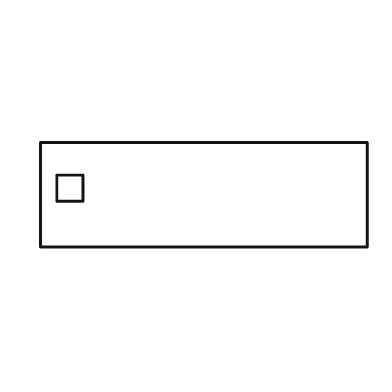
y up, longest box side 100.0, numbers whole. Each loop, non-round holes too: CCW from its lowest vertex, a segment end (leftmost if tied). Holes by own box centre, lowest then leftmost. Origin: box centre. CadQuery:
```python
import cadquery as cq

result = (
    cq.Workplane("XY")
    .moveTo(-50.0, -16.0)
    .lineTo(50.0, -16.0)
    .lineTo(50.0, 16.0)
    .lineTo(-50.0, 16.0)
    .close()
    .moveTo(-45.0, -2.0)
    .lineTo(-37.0, -2.0)
    .lineTo(-37.0, 6.0)
    .lineTo(-45.0, 6.0)
    .close()
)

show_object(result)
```